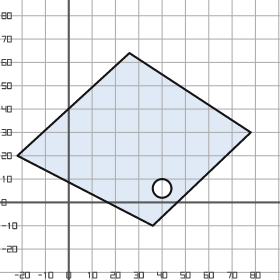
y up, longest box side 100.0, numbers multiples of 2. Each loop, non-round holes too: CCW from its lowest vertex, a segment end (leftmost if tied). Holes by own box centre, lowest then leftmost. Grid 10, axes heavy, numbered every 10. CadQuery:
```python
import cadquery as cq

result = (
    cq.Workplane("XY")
    .moveTo(36.0, -10.0)
    .lineTo(78.0, 30.0)
    .lineTo(26.0, 64.0)
    .lineTo(-22.0, 20.0)
    .close()
    .moveTo(40.0, 6.0)
    .circle(4.0)
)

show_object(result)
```